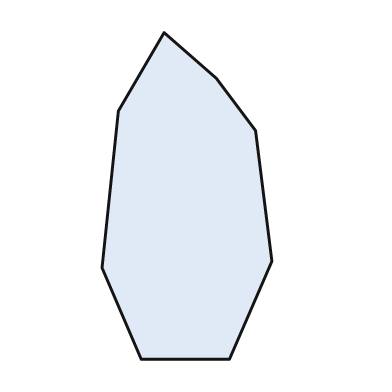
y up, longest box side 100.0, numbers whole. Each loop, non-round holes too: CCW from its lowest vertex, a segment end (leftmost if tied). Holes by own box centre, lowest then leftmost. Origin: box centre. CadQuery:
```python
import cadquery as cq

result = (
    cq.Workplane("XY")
    .moveTo(-14.0, -50.0)
    .lineTo(13.0, -50.0)
    .lineTo(26.0, -20.0)
    .lineTo(21.0, 20.0)
    .lineTo(9.0, 36.0)
    .lineTo(-7.0, 50.0)
    .lineTo(-21.0, 26.0)
    .lineTo(-26.0, -22.0)
    .close()
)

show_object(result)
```